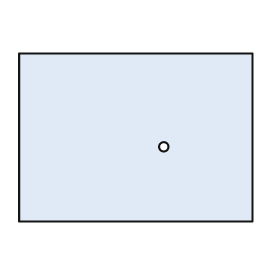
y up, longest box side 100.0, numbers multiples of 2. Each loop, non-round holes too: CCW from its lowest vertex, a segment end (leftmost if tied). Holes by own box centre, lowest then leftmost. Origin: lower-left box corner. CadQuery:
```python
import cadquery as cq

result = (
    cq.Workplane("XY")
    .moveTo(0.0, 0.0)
    .lineTo(100.0, 0.0)
    .lineTo(100.0, 72.0)
    .lineTo(0.0, 72.0)
    .close()
    .moveTo(62.0, 32.0)
    .circle(2.0)
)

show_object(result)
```